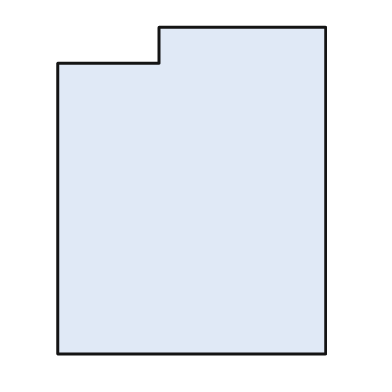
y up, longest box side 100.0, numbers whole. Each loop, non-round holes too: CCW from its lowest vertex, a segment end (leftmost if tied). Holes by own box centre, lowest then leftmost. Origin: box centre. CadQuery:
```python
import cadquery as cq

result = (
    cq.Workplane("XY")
    .moveTo(-41.0, -50.0)
    .lineTo(41.0, -50.0)
    .lineTo(41.0, 50.0)
    .lineTo(-10.0, 50.0)
    .lineTo(-10.0, 39.0)
    .lineTo(-41.0, 39.0)
    .close()
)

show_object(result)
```